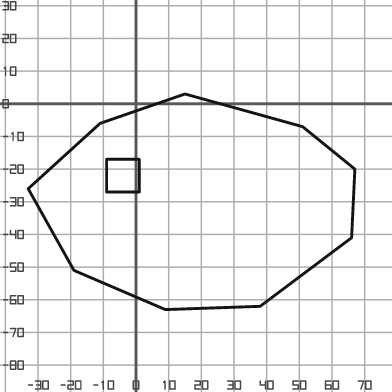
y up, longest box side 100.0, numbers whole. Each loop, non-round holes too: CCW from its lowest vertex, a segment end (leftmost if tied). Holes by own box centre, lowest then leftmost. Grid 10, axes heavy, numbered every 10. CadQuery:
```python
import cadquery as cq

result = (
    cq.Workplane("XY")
    .moveTo(9.0, -63.0)
    .lineTo(38.0, -62.0)
    .lineTo(66.0, -41.0)
    .lineTo(67.0, -20.0)
    .lineTo(51.0, -7.0)
    .lineTo(15.0, 3.0)
    .lineTo(-11.0, -6.0)
    .lineTo(-33.0, -26.0)
    .lineTo(-19.0, -51.0)
    .close()
    .moveTo(-9.0, -27.0)
    .lineTo(1.0, -27.0)
    .lineTo(1.0, -17.0)
    .lineTo(-9.0, -17.0)
    .close()
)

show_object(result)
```